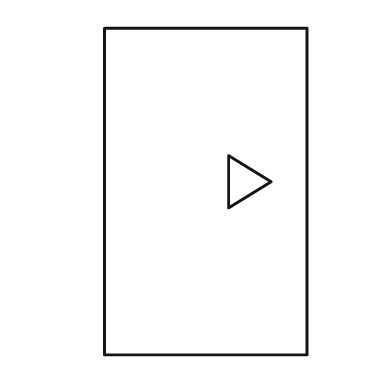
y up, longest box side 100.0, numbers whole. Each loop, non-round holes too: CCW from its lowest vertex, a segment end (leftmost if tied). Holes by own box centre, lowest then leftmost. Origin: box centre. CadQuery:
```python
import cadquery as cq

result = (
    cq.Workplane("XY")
    .moveTo(-31.0, -50.0)
    .lineTo(31.0, -50.0)
    .lineTo(31.0, 50.0)
    .lineTo(-31.0, 50.0)
    .close()
    .moveTo(7.0, -5.0)
    .lineTo(20.0, 3.0)
    .lineTo(7.0, 11.0)
    .close()
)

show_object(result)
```